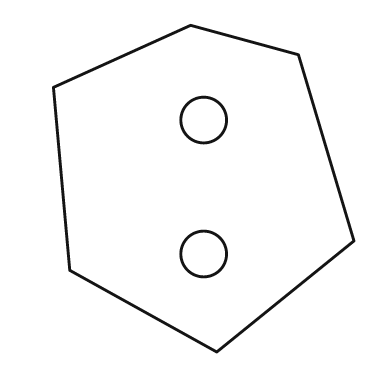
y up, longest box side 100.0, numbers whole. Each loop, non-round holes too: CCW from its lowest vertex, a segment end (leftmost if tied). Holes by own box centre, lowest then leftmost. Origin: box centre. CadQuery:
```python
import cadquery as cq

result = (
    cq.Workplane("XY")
    .moveTo(4.0, -50.0)
    .lineTo(46.0, -16.0)
    .lineTo(29.0, 41.0)
    .lineTo(-4.0, 50.0)
    .lineTo(-46.0, 31.0)
    .lineTo(-41.0, -25.0)
    .close()
    .moveTo(0.0, -20.0)
    .circle(7.0)
    .moveTo(0.0, 21.0)
    .circle(7.0)
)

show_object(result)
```